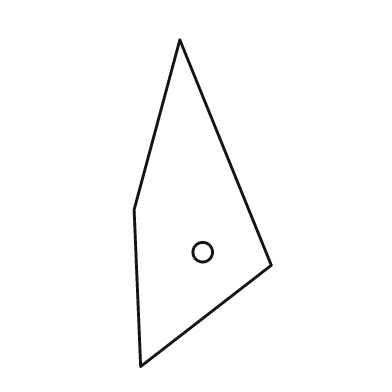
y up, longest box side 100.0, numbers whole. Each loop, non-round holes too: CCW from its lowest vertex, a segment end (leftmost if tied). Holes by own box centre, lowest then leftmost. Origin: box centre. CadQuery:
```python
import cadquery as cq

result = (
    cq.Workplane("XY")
    .moveTo(-19.0, -50.0)
    .lineTo(21.0, -19.0)
    .lineTo(-7.0, 50.0)
    .lineTo(-21.0, -2.0)
    .close()
    .moveTo(0.0, -15.0)
    .circle(3.0)
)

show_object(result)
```